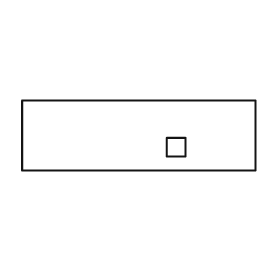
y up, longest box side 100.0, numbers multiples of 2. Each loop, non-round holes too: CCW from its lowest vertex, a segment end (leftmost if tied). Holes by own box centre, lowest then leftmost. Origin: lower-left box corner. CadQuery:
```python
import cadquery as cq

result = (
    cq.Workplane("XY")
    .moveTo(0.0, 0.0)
    .lineTo(100.0, 0.0)
    .lineTo(100.0, 30.0)
    .lineTo(0.0, 30.0)
    .close()
    .moveTo(62.0, 6.0)
    .lineTo(70.0, 6.0)
    .lineTo(70.0, 14.0)
    .lineTo(62.0, 14.0)
    .close()
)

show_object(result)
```